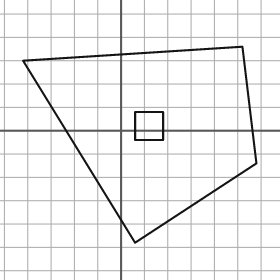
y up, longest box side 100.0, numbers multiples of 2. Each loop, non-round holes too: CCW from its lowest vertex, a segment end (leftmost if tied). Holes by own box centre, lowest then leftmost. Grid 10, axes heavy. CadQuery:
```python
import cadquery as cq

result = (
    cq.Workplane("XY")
    .moveTo(6.0, -48.0)
    .lineTo(58.0, -14.0)
    .lineTo(52.0, 36.0)
    .lineTo(-42.0, 30.0)
    .close()
    .moveTo(6.0, -4.0)
    .lineTo(18.0, -4.0)
    .lineTo(18.0, 8.0)
    .lineTo(6.0, 8.0)
    .close()
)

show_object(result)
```